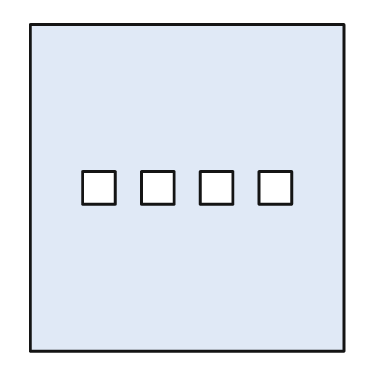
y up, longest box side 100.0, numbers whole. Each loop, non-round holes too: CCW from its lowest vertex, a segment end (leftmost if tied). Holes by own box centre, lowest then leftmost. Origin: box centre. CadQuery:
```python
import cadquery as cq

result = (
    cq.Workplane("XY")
    .moveTo(-48.0, -50.0)
    .lineTo(48.0, -50.0)
    .lineTo(48.0, 50.0)
    .lineTo(-48.0, 50.0)
    .close()
    .moveTo(-32.0, -5.0)
    .lineTo(-22.0, -5.0)
    .lineTo(-22.0, 5.0)
    .lineTo(-32.0, 5.0)
    .close()
    .moveTo(-14.0, -5.0)
    .lineTo(-4.0, -5.0)
    .lineTo(-4.0, 5.0)
    .lineTo(-14.0, 5.0)
    .close()
    .moveTo(4.0, -5.0)
    .lineTo(14.0, -5.0)
    .lineTo(14.0, 5.0)
    .lineTo(4.0, 5.0)
    .close()
    .moveTo(22.0, -5.0)
    .lineTo(32.0, -5.0)
    .lineTo(32.0, 5.0)
    .lineTo(22.0, 5.0)
    .close()
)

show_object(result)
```